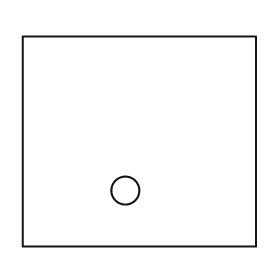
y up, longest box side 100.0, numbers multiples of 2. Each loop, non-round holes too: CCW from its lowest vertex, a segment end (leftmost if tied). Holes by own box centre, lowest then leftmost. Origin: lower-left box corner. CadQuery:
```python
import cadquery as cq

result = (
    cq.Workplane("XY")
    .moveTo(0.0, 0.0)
    .lineTo(100.0, 0.0)
    .lineTo(100.0, 90.0)
    .lineTo(0.0, 90.0)
    .close()
    .moveTo(44.0, 24.0)
    .circle(6.0)
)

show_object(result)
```